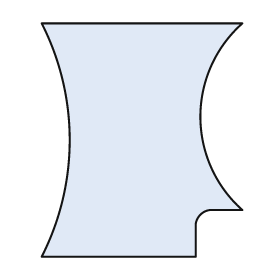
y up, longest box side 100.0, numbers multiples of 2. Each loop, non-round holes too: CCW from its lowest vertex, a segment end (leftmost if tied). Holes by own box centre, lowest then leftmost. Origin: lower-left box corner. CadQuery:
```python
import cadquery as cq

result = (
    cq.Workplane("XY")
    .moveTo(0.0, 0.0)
    .lineTo(66.0, 0.0)
    .lineTo(66.0, 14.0)
    .threePointArc((68.0, 18.0), (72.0, 20.0))
    .lineTo(86.0, 20.0)
    .threePointArc((68.0, 60.0), (86.0, 100.0))
    .lineTo(0.0, 100.0)
    .threePointArc((12.0, 50.0), (0.0, 0.0))
    .close()
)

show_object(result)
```